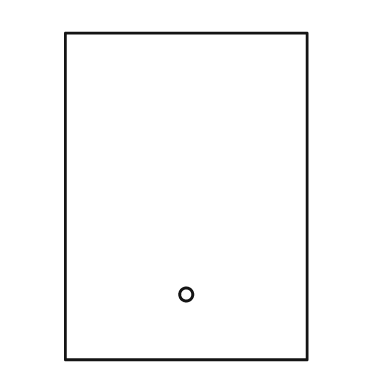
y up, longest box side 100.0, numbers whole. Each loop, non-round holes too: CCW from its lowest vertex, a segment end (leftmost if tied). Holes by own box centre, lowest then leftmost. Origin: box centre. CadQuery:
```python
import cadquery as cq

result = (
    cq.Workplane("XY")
    .moveTo(-37.0, -50.0)
    .lineTo(37.0, -50.0)
    .lineTo(37.0, 50.0)
    .lineTo(-37.0, 50.0)
    .close()
    .moveTo(0.0, -30.0)
    .circle(2.0)
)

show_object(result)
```